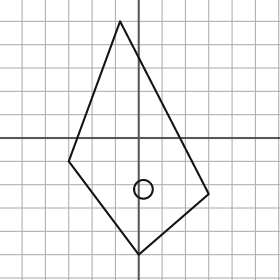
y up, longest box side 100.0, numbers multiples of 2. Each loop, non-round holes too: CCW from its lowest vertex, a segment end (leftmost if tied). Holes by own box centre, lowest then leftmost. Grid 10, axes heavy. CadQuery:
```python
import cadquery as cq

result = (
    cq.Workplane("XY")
    .moveTo(0.0, -50.0)
    .lineTo(30.0, -24.0)
    .lineTo(-8.0, 50.0)
    .lineTo(-30.0, -10.0)
    .close()
    .moveTo(2.0, -22.0)
    .circle(4.0)
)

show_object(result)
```